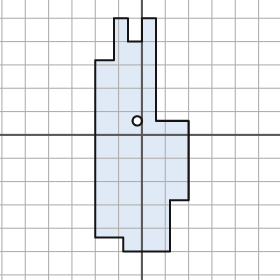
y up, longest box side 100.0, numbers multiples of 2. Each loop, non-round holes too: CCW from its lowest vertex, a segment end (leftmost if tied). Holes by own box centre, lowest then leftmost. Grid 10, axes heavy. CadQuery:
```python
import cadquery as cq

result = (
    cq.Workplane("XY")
    .moveTo(-8.0, -50.0)
    .lineTo(12.0, -50.0)
    .lineTo(12.0, -28.0)
    .lineTo(20.0, -28.0)
    .lineTo(20.0, 6.0)
    .lineTo(6.0, 6.0)
    .lineTo(6.0, 50.0)
    .lineTo(0.0, 50.0)
    .lineTo(0.0, 40.0)
    .lineTo(-6.0, 40.0)
    .lineTo(-6.0, 50.0)
    .lineTo(-12.0, 50.0)
    .lineTo(-12.0, 32.0)
    .lineTo(-20.0, 32.0)
    .lineTo(-20.0, -44.0)
    .lineTo(-8.0, -44.0)
    .close()
    .moveTo(-2.0, 6.0)
    .circle(2.0)
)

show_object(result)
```